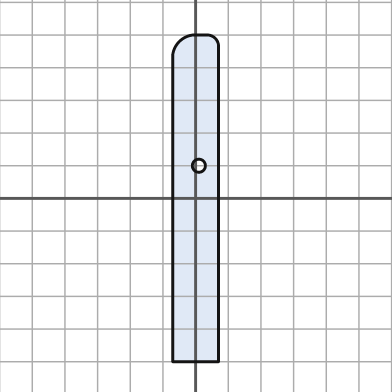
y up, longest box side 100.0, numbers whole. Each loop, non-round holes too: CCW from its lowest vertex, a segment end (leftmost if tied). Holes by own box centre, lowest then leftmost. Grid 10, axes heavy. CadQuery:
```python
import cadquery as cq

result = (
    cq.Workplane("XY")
    .moveTo(-7.0, -50.0)
    .lineTo(7.0, -50.0)
    .lineTo(7.0, 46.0)
    .threePointArc((6.0, 49.0), (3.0, 50.0))
    .lineTo(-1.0, 50.0)
    .threePointArc((-5.0, 48.0), (-7.0, 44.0))
    .close()
    .moveTo(1.0, 10.0)
    .circle(2.0)
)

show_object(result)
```